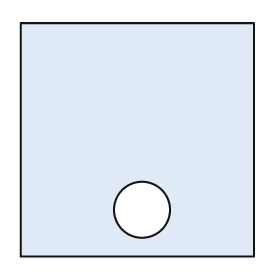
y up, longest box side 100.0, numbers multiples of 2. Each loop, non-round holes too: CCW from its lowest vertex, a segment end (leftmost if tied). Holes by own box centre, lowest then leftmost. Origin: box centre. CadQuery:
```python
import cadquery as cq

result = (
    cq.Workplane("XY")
    .moveTo(-50.0, -50.0)
    .lineTo(50.0, -50.0)
    .lineTo(50.0, 50.0)
    .lineTo(-50.0, 50.0)
    .close()
    .moveTo(2.0, -30.0)
    .circle(12.0)
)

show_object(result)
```